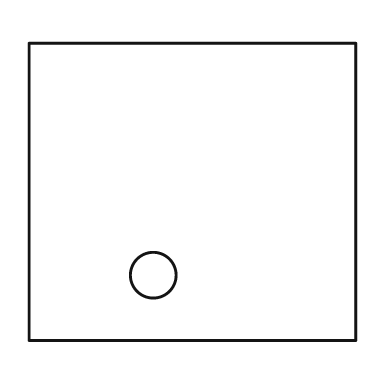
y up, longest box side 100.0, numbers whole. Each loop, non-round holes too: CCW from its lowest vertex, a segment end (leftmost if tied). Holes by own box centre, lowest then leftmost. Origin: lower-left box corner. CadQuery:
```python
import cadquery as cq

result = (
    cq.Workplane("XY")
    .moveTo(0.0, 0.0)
    .lineTo(100.0, 0.0)
    .lineTo(100.0, 91.0)
    .lineTo(0.0, 91.0)
    .close()
    .moveTo(38.0, 20.0)
    .circle(7.0)
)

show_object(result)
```